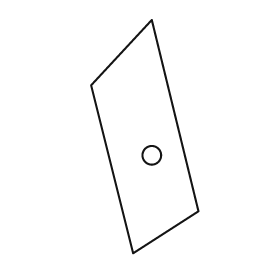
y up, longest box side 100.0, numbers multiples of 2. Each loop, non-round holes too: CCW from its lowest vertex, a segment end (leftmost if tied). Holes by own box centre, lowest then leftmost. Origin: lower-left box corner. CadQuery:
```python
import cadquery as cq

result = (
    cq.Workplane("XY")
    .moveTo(18.0, 0.0)
    .lineTo(46.0, 18.0)
    .lineTo(26.0, 100.0)
    .lineTo(0.0, 72.0)
    .close()
    .moveTo(26.0, 42.0)
    .circle(4.0)
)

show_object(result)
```